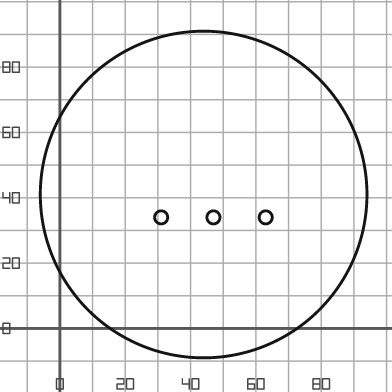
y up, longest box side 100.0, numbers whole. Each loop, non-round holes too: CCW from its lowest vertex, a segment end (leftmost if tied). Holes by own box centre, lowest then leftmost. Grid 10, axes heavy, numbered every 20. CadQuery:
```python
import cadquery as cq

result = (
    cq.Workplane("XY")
    .moveTo(44.0, 41.0)
    .circle(50.0)
    .moveTo(31.0, 34.0)
    .circle(2.0)
    .moveTo(47.0, 34.0)
    .circle(2.0)
    .moveTo(63.0, 34.0)
    .circle(2.0)
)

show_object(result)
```